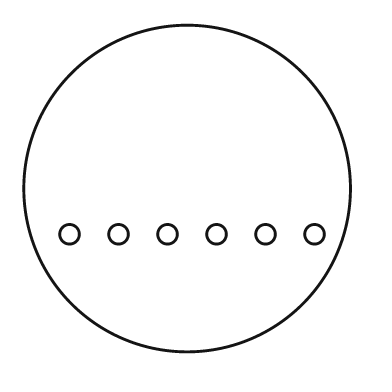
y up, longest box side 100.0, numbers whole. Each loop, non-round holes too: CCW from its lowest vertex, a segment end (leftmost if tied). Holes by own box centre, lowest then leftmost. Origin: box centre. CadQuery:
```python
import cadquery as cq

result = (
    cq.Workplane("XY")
    .moveTo(0.0, 0.0)
    .circle(50.0)
    .moveTo(-36.0, -14.0)
    .circle(3.0)
    .moveTo(-21.0, -14.0)
    .circle(3.0)
    .moveTo(-6.0, -14.0)
    .circle(3.0)
    .moveTo(9.0, -14.0)
    .circle(3.0)
    .moveTo(24.0, -14.0)
    .circle(3.0)
    .moveTo(39.0, -14.0)
    .circle(3.0)
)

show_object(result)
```